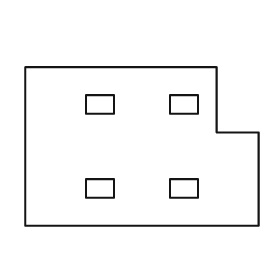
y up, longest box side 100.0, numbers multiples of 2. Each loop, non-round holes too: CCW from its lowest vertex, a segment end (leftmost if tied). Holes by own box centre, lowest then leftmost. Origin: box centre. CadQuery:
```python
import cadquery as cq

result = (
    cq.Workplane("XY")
    .moveTo(-50.0, -34.0)
    .lineTo(50.0, -34.0)
    .lineTo(50.0, 6.0)
    .lineTo(32.0, 6.0)
    .lineTo(32.0, 34.0)
    .lineTo(-50.0, 34.0)
    .close()
    .moveTo(-24.0, -22.0)
    .lineTo(-12.0, -22.0)
    .lineTo(-12.0, -14.0)
    .lineTo(-24.0, -14.0)
    .close()
    .moveTo(12.0, -22.0)
    .lineTo(24.0, -22.0)
    .lineTo(24.0, -14.0)
    .lineTo(12.0, -14.0)
    .close()
    .moveTo(-24.0, 14.0)
    .lineTo(-12.0, 14.0)
    .lineTo(-12.0, 22.0)
    .lineTo(-24.0, 22.0)
    .close()
    .moveTo(12.0, 14.0)
    .lineTo(24.0, 14.0)
    .lineTo(24.0, 22.0)
    .lineTo(12.0, 22.0)
    .close()
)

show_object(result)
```